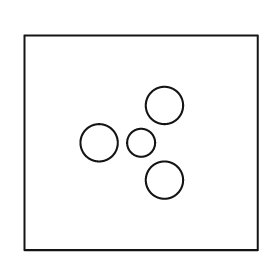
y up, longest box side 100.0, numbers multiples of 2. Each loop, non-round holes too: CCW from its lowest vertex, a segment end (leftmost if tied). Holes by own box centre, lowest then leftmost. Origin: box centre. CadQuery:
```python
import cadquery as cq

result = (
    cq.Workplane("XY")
    .moveTo(-50.0, -46.0)
    .lineTo(50.0, -46.0)
    .lineTo(50.0, 46.0)
    .lineTo(-50.0, 46.0)
    .close()
    .moveTo(10.0, -16.0)
    .circle(8.0)
    .moveTo(-18.0, 0.0)
    .circle(8.0)
    .moveTo(0.0, 0.0)
    .circle(6.0)
    .moveTo(10.0, 16.0)
    .circle(8.0)
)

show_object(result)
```